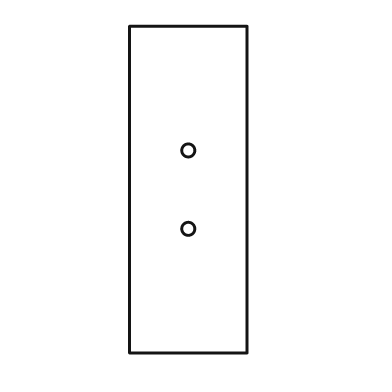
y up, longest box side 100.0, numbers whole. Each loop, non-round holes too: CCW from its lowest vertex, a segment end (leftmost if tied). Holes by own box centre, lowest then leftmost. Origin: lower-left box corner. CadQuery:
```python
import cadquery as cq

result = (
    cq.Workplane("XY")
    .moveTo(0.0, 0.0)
    .lineTo(36.0, 0.0)
    .lineTo(36.0, 100.0)
    .lineTo(0.0, 100.0)
    .close()
    .moveTo(18.0, 38.0)
    .circle(2.0)
    .moveTo(18.0, 62.0)
    .circle(2.0)
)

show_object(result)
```